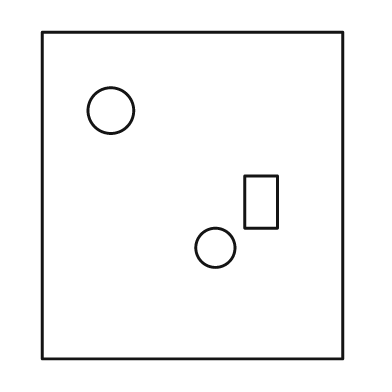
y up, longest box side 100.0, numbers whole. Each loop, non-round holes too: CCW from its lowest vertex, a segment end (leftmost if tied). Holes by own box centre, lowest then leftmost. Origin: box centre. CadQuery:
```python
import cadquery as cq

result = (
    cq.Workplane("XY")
    .moveTo(-46.0, -50.0)
    .lineTo(46.0, -50.0)
    .lineTo(46.0, 50.0)
    .lineTo(-46.0, 50.0)
    .close()
    .moveTo(7.0, -16.0)
    .circle(6.0)
    .moveTo(16.0, -10.0)
    .lineTo(26.0, -10.0)
    .lineTo(26.0, 6.0)
    .lineTo(16.0, 6.0)
    .close()
    .moveTo(-25.0, 26.0)
    .circle(7.0)
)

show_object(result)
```